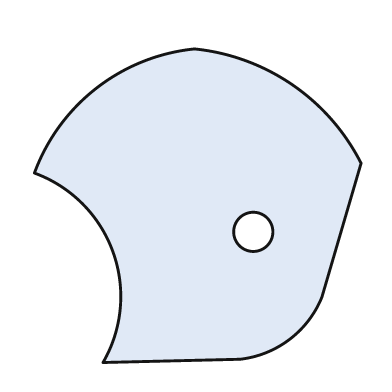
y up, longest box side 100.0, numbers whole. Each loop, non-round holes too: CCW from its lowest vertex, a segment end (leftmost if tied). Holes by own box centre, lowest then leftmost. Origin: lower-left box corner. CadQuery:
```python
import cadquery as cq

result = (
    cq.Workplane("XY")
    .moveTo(21.0, 0.0)
    .lineTo(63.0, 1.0)
    .threePointArc((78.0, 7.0), (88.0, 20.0))
    .lineTo(100.0, 61.0)
    .threePointArc((79.0, 85.0), (49.0, 96.0))
    .threePointArc((19.0, 84.0), (0.0, 58.0))
    .threePointArc((24.0, 34.0), (21.0, 0.0))
    .close()
    .moveTo(67.0, 40.0)
    .circle(6.0)
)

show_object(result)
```